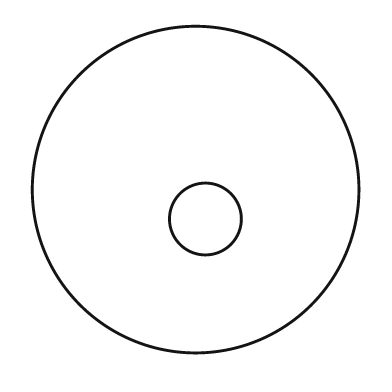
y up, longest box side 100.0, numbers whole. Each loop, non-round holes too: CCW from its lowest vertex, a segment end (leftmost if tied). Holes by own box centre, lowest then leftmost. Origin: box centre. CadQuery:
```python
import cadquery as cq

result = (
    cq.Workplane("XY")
    .moveTo(0.0, 0.0)
    .circle(50.0)
    .moveTo(3.0, -9.0)
    .circle(11.0)
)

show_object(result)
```